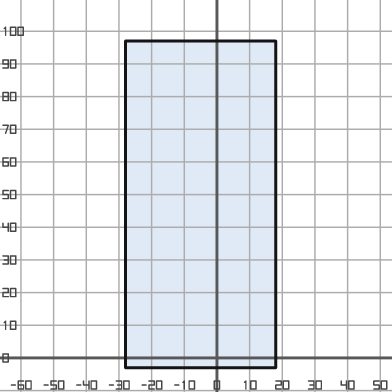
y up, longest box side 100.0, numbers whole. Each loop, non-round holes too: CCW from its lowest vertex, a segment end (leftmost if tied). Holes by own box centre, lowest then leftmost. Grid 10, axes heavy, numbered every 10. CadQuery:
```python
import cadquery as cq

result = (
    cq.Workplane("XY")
    .moveTo(-28.0, -3.0)
    .lineTo(18.0, -3.0)
    .lineTo(18.0, 97.0)
    .lineTo(-28.0, 97.0)
    .close()
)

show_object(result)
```